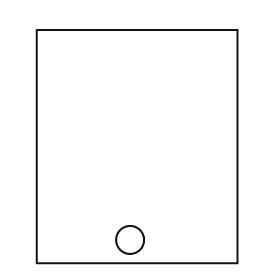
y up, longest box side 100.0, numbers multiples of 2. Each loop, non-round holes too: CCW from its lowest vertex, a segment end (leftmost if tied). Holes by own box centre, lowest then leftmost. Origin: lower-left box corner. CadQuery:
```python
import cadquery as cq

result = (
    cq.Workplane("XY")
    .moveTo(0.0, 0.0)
    .lineTo(86.0, 0.0)
    .lineTo(86.0, 100.0)
    .lineTo(0.0, 100.0)
    .close()
    .moveTo(40.0, 10.0)
    .circle(6.0)
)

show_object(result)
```